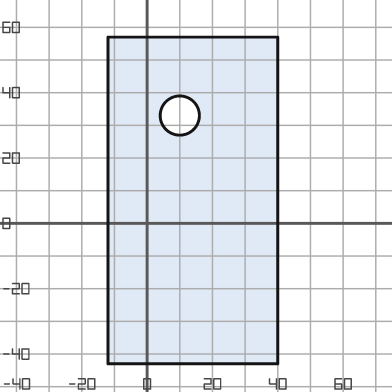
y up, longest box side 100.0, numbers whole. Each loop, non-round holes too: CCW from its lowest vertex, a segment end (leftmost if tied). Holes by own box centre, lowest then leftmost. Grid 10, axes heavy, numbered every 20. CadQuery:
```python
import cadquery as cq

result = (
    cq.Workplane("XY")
    .moveTo(-12.0, -43.0)
    .lineTo(40.0, -43.0)
    .lineTo(40.0, 57.0)
    .lineTo(-12.0, 57.0)
    .close()
    .moveTo(10.0, 33.0)
    .circle(6.0)
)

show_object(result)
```